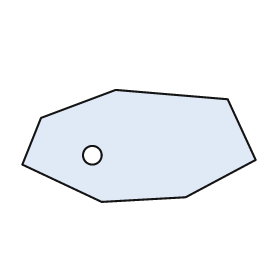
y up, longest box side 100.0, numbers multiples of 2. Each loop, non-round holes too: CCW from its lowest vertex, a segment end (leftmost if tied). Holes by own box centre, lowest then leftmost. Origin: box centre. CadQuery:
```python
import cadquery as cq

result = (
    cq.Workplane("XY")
    .moveTo(-16.0, -24.0)
    .lineTo(20.0, -22.0)
    .lineTo(50.0, -6.0)
    .lineTo(38.0, 20.0)
    .lineTo(-10.0, 24.0)
    .lineTo(-42.0, 12.0)
    .lineTo(-50.0, -8.0)
    .close()
    .moveTo(-20.0, -4.0)
    .circle(4.0)
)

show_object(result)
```